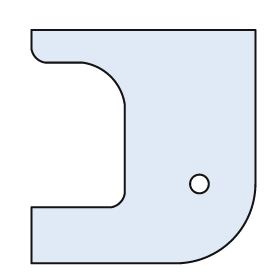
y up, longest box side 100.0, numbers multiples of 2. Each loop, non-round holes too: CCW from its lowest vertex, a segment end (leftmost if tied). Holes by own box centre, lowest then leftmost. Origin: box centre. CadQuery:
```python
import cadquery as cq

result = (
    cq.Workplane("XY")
    .moveTo(-48.0, -50.0)
    .lineTo(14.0, -50.0)
    .threePointArc((38.0, -40.0), (48.0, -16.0))
    .lineTo(48.0, 50.0)
    .lineTo(-48.0, 50.0)
    .lineTo(-48.0, 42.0)
    .threePointArc((-46.0, 38.0), (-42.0, 36.0))
    .lineTo(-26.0, 36.0)
    .threePointArc((-14.0, 30.0), (-8.0, 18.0))
    .lineTo(-8.0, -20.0)
    .threePointArc((-10.0, -24.0), (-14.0, -26.0))
    .lineTo(-48.0, -26.0)
    .close()
    .moveTo(24.0, -16.0)
    .circle(4.0)
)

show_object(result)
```